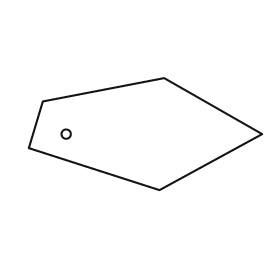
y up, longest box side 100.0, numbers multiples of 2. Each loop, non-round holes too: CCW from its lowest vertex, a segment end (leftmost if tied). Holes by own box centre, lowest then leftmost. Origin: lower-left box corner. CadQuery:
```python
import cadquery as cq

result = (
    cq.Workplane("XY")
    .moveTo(56.0, 0.0)
    .lineTo(100.0, 24.0)
    .lineTo(58.0, 48.0)
    .lineTo(6.0, 38.0)
    .lineTo(0.0, 18.0)
    .close()
    .moveTo(16.0, 24.0)
    .circle(2.0)
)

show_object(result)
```